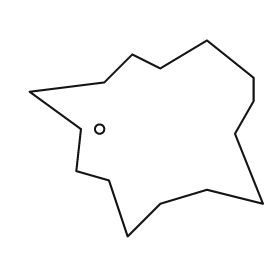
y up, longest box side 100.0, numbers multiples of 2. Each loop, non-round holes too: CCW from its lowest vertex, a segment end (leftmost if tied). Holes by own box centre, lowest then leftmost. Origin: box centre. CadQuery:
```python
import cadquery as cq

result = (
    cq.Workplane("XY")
    .moveTo(-8.0, -42.0)
    .lineTo(6.0, -28.0)
    .lineTo(26.0, -22.0)
    .lineTo(50.0, -28.0)
    .lineTo(38.0, 2.0)
    .lineTo(46.0, 16.0)
    .lineTo(46.0, 26.0)
    .lineTo(26.0, 42.0)
    .lineTo(6.0, 30.0)
    .lineTo(-6.0, 36.0)
    .lineTo(-18.0, 24.0)
    .lineTo(-50.0, 20.0)
    .lineTo(-28.0, 4.0)
    .lineTo(-30.0, -14.0)
    .lineTo(-16.0, -18.0)
    .close()
    .moveTo(-20.0, 4.0)
    .circle(2.0)
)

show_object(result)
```